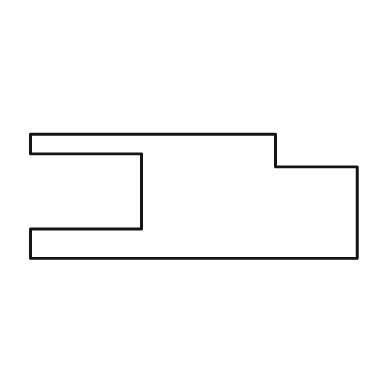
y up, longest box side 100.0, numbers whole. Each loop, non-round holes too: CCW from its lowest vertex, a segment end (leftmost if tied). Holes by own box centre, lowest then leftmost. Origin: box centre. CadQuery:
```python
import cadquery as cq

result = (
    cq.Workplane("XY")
    .moveTo(-50.0, -19.0)
    .lineTo(50.0, -19.0)
    .lineTo(50.0, 9.0)
    .lineTo(25.0, 9.0)
    .lineTo(25.0, 19.0)
    .lineTo(-50.0, 19.0)
    .lineTo(-50.0, 13.0)
    .lineTo(-16.0, 13.0)
    .lineTo(-16.0, -10.0)
    .lineTo(-50.0, -10.0)
    .close()
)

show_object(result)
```